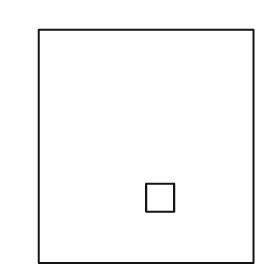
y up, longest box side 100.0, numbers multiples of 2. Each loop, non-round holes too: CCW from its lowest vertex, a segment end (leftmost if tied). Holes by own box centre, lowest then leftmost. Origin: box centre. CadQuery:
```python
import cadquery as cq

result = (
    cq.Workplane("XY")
    .moveTo(-46.0, -50.0)
    .lineTo(46.0, -50.0)
    .lineTo(46.0, 50.0)
    .lineTo(-46.0, 50.0)
    .close()
    .moveTo(0.0, -28.0)
    .lineTo(12.0, -28.0)
    .lineTo(12.0, -16.0)
    .lineTo(0.0, -16.0)
    .close()
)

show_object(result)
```